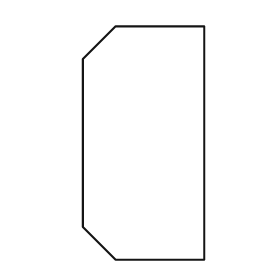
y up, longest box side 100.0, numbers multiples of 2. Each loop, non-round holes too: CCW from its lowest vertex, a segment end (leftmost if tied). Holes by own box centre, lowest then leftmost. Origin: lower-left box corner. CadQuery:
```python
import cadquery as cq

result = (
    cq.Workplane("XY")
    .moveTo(14.0, 0.0)
    .lineTo(52.0, 0.0)
    .lineTo(52.0, 100.0)
    .lineTo(14.0, 100.0)
    .lineTo(0.0, 86.0)
    .lineTo(0.0, 14.0)
    .close()
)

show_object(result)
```